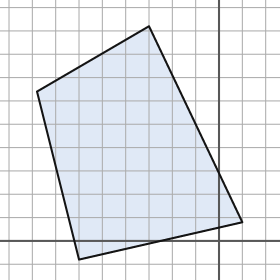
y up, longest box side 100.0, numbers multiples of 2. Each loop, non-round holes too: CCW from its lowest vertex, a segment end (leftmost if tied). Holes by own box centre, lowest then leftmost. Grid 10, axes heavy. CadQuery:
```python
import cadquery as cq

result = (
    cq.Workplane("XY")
    .moveTo(-60.0, -8.0)
    .lineTo(10.0, 8.0)
    .lineTo(-30.0, 92.0)
    .lineTo(-78.0, 64.0)
    .close()
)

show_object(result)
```